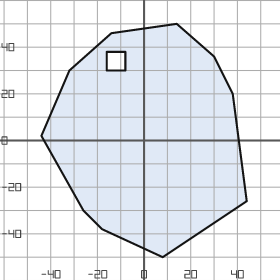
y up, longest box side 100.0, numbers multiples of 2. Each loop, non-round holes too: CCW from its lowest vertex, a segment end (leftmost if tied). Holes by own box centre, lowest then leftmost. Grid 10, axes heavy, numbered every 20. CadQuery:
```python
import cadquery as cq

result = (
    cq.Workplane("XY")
    .moveTo(8.0, -50.0)
    .lineTo(44.0, -26.0)
    .lineTo(38.0, 20.0)
    .lineTo(30.0, 36.0)
    .lineTo(14.0, 50.0)
    .lineTo(-14.0, 46.0)
    .lineTo(-32.0, 30.0)
    .lineTo(-44.0, 2.0)
    .lineTo(-26.0, -30.0)
    .lineTo(-18.0, -38.0)
    .close()
    .moveTo(-16.0, 30.0)
    .lineTo(-8.0, 30.0)
    .lineTo(-8.0, 38.0)
    .lineTo(-16.0, 38.0)
    .close()
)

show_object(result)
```